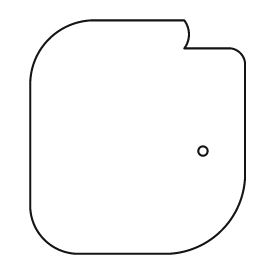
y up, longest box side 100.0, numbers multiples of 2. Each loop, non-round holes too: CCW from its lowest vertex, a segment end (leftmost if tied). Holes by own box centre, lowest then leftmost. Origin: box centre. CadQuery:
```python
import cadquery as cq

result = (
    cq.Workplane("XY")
    .moveTo(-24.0, -50.0)
    .lineTo(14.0, -50.0)
    .threePointArc((36.0, -40.0), (46.0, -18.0))
    .lineTo(46.0, 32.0)
    .threePointArc((44.0, 36.0), (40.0, 38.0))
    .lineTo(20.0, 38.0)
    .threePointArc((22.0, 44.0), (20.0, 50.0))
    .lineTo(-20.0, 50.0)
    .threePointArc((-38.0, 42.0), (-46.0, 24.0))
    .lineTo(-46.0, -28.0)
    .threePointArc((-40.0, -44.0), (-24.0, -50.0))
    .close()
    .moveTo(28.0, -6.0)
    .circle(2.0)
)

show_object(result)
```